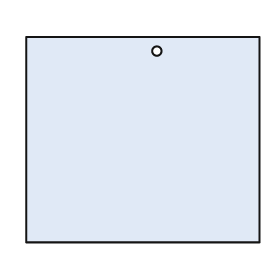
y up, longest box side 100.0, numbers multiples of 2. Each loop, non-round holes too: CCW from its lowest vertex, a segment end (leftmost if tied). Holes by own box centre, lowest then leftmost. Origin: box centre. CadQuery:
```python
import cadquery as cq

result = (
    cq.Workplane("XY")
    .moveTo(-50.0, -44.0)
    .lineTo(50.0, -44.0)
    .lineTo(50.0, 44.0)
    .lineTo(-50.0, 44.0)
    .close()
    .moveTo(6.0, 38.0)
    .circle(2.0)
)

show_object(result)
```